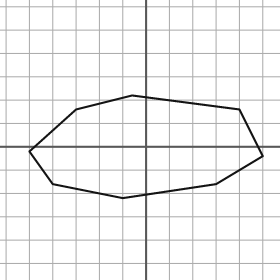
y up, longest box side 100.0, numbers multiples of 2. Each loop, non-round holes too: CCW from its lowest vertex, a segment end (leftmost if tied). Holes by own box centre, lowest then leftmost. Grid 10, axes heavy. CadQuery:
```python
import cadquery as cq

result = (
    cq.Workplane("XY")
    .moveTo(-10.0, -22.0)
    .lineTo(30.0, -16.0)
    .lineTo(50.0, -4.0)
    .lineTo(40.0, 16.0)
    .lineTo(-6.0, 22.0)
    .lineTo(-30.0, 16.0)
    .lineTo(-50.0, -2.0)
    .lineTo(-40.0, -16.0)
    .close()
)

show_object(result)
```